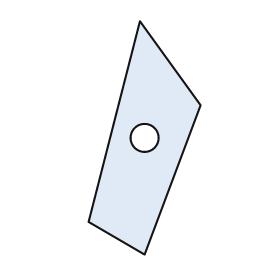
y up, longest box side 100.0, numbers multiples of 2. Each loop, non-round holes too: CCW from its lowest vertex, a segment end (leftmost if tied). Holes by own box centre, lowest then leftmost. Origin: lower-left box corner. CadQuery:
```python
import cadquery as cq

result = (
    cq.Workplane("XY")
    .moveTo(24.0, 0.0)
    .lineTo(48.0, 64.0)
    .lineTo(22.0, 100.0)
    .lineTo(0.0, 14.0)
    .close()
    .moveTo(24.0, 50.0)
    .circle(6.0)
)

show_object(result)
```